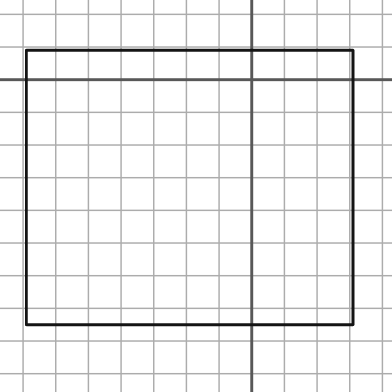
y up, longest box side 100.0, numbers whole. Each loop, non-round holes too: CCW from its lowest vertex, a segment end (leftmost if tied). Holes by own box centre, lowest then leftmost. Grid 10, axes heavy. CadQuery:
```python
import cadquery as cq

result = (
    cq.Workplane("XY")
    .moveTo(-69.0, -75.0)
    .lineTo(31.0, -75.0)
    .lineTo(31.0, 9.0)
    .lineTo(-69.0, 9.0)
    .close()
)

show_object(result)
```